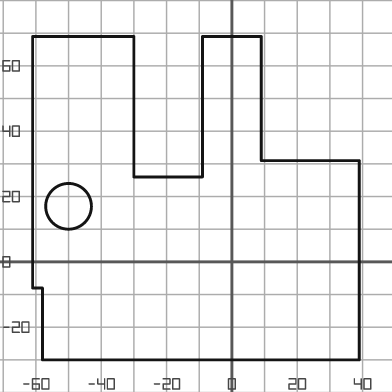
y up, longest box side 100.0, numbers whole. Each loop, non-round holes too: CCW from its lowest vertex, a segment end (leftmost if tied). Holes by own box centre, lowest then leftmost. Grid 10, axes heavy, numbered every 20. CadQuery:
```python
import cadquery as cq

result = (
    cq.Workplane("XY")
    .moveTo(-58.0, -30.0)
    .lineTo(39.0, -30.0)
    .lineTo(39.0, 31.0)
    .lineTo(9.0, 31.0)
    .lineTo(9.0, 69.0)
    .lineTo(-9.0, 69.0)
    .lineTo(-9.0, 26.0)
    .lineTo(-30.0, 26.0)
    .lineTo(-30.0, 69.0)
    .lineTo(-61.0, 69.0)
    .lineTo(-61.0, -8.0)
    .lineTo(-58.0, -8.0)
    .close()
    .moveTo(-50.0, 17.0)
    .circle(7.0)
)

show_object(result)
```